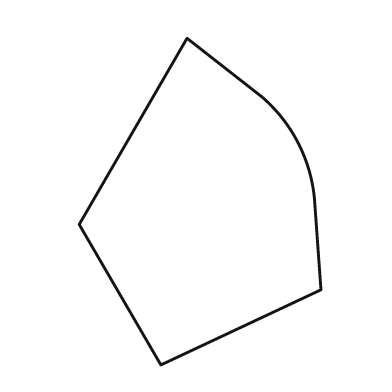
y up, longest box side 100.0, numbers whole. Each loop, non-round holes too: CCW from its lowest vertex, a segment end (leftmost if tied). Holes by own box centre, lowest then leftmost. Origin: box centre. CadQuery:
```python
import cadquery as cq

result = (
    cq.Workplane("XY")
    .moveTo(-12.0, -50.0)
    .lineTo(37.0, -27.0)
    .lineTo(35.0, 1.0)
    .threePointArc((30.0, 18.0), (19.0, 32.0))
    .lineTo(-4.0, 50.0)
    .lineTo(-37.0, -7.0)
    .close()
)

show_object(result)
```